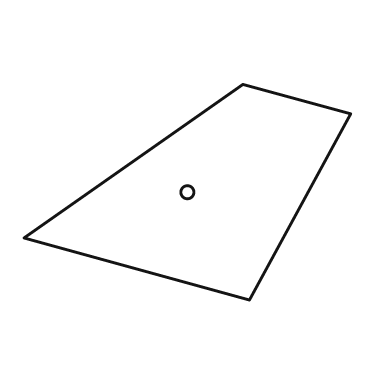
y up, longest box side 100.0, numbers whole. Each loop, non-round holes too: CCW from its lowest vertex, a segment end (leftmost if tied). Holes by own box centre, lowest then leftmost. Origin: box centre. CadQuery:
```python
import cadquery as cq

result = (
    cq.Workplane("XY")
    .moveTo(19.0, -33.0)
    .lineTo(50.0, 24.0)
    .lineTo(17.0, 33.0)
    .lineTo(-50.0, -14.0)
    .close()
    .moveTo(0.0, 0.0)
    .circle(2.0)
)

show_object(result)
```